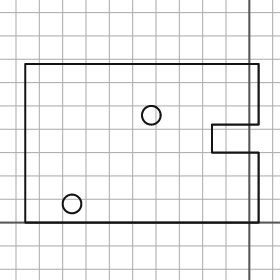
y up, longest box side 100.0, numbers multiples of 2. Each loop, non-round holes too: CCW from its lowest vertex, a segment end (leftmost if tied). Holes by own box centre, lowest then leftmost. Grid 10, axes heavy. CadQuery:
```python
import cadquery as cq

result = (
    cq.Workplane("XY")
    .moveTo(-96.0, 0.0)
    .lineTo(4.0, 0.0)
    .lineTo(4.0, 30.0)
    .lineTo(-16.0, 30.0)
    .lineTo(-16.0, 42.0)
    .lineTo(4.0, 42.0)
    .lineTo(4.0, 68.0)
    .lineTo(-96.0, 68.0)
    .close()
    .moveTo(-76.0, 8.0)
    .circle(4.0)
    .moveTo(-42.0, 46.0)
    .circle(4.0)
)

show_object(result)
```